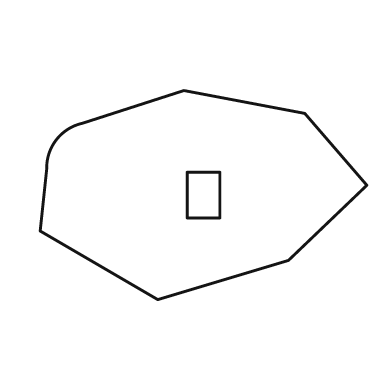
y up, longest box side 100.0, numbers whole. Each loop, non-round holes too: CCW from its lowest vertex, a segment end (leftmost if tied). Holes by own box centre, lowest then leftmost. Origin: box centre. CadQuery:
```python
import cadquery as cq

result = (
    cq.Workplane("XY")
    .moveTo(-14.0, -32.0)
    .lineTo(26.0, -20.0)
    .lineTo(50.0, 3.0)
    .lineTo(31.0, 25.0)
    .lineTo(-6.0, 32.0)
    .lineTo(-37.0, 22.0)
    .threePointArc((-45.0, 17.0), (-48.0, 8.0))
    .lineTo(-50.0, -11.0)
    .close()
    .moveTo(-5.0, -7.0)
    .lineTo(5.0, -7.0)
    .lineTo(5.0, 7.0)
    .lineTo(-5.0, 7.0)
    .close()
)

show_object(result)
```